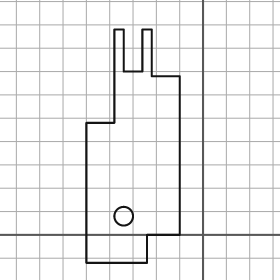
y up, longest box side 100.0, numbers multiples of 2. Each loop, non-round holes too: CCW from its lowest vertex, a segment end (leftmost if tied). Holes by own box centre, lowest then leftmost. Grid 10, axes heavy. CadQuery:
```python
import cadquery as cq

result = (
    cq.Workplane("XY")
    .moveTo(-50.0, -12.0)
    .lineTo(-24.0, -12.0)
    .lineTo(-24.0, 0.0)
    .lineTo(-10.0, 0.0)
    .lineTo(-10.0, 68.0)
    .lineTo(-22.0, 68.0)
    .lineTo(-22.0, 88.0)
    .lineTo(-26.0, 88.0)
    .lineTo(-26.0, 70.0)
    .lineTo(-34.0, 70.0)
    .lineTo(-34.0, 88.0)
    .lineTo(-38.0, 88.0)
    .lineTo(-38.0, 48.0)
    .lineTo(-50.0, 48.0)
    .close()
    .moveTo(-34.0, 8.0)
    .circle(4.0)
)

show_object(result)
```